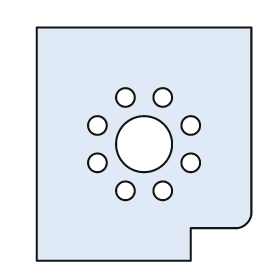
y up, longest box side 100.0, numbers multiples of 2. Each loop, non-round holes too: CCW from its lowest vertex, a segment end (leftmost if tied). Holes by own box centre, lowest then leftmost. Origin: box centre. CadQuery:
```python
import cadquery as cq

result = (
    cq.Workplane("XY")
    .moveTo(-46.0, -50.0)
    .lineTo(20.0, -50.0)
    .lineTo(20.0, -36.0)
    .lineTo(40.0, -36.0)
    .threePointArc((44.0, -34.0), (46.0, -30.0))
    .lineTo(46.0, 50.0)
    .lineTo(-46.0, 50.0)
    .close()
    .moveTo(-8.0, -20.0)
    .circle(4.0)
    .moveTo(8.0, -20.0)
    .circle(4.0)
    .moveTo(-20.0, -8.0)
    .circle(4.0)
    .moveTo(20.0, -8.0)
    .circle(4.0)
    .moveTo(0.0, 0.0)
    .circle(12.0)
    .moveTo(-20.0, 8.0)
    .circle(4.0)
    .moveTo(20.0, 8.0)
    .circle(4.0)
    .moveTo(-8.0, 20.0)
    .circle(4.0)
    .moveTo(8.0, 20.0)
    .circle(4.0)
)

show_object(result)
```